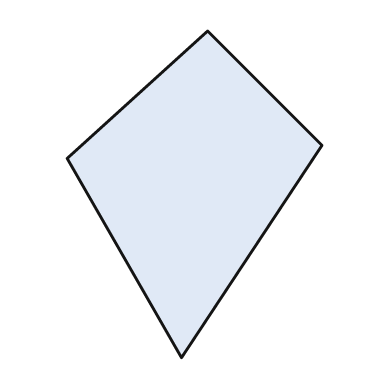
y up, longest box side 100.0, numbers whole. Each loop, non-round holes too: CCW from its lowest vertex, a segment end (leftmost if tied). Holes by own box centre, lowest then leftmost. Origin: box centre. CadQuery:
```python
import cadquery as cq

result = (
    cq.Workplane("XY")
    .moveTo(-4.0, -50.0)
    .lineTo(39.0, 15.0)
    .lineTo(4.0, 50.0)
    .lineTo(-39.0, 11.0)
    .close()
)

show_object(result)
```